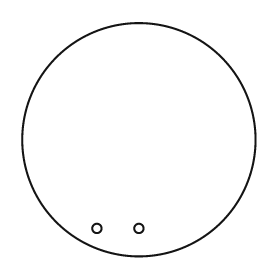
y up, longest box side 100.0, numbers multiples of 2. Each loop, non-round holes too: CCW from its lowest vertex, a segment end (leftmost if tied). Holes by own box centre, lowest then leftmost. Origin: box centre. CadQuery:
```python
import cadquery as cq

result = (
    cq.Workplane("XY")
    .moveTo(0.0, 0.0)
    .circle(50.0)
    .moveTo(-18.0, -38.0)
    .circle(2.0)
    .moveTo(0.0, -38.0)
    .circle(2.0)
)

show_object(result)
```